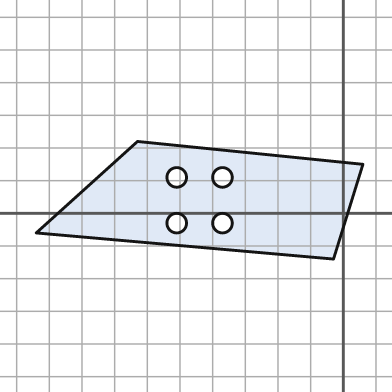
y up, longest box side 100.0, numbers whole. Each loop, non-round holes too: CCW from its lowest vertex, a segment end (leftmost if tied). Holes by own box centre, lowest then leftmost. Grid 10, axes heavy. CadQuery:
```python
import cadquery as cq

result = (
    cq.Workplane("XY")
    .moveTo(-3.0, -14.0)
    .lineTo(6.0, 15.0)
    .lineTo(-63.0, 22.0)
    .lineTo(-94.0, -6.0)
    .close()
    .moveTo(-51.0, -3.0)
    .circle(3.0)
    .moveTo(-37.0, -3.0)
    .circle(3.0)
    .moveTo(-51.0, 11.0)
    .circle(3.0)
    .moveTo(-37.0, 11.0)
    .circle(3.0)
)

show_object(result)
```